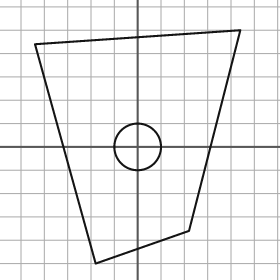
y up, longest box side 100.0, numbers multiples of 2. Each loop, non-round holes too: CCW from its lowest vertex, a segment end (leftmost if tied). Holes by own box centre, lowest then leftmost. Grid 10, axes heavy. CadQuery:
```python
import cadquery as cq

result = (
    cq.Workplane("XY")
    .moveTo(-18.0, -50.0)
    .lineTo(22.0, -36.0)
    .lineTo(44.0, 50.0)
    .lineTo(-44.0, 44.0)
    .close()
    .moveTo(0.0, 0.0)
    .circle(10.0)
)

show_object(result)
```